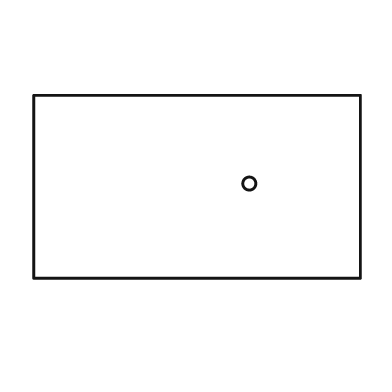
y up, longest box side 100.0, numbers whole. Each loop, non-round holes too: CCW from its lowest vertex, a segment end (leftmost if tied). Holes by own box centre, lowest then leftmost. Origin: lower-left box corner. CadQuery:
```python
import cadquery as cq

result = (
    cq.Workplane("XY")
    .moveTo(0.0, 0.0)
    .lineTo(100.0, 0.0)
    .lineTo(100.0, 56.0)
    .lineTo(0.0, 56.0)
    .close()
    .moveTo(66.0, 29.0)
    .circle(2.0)
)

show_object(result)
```